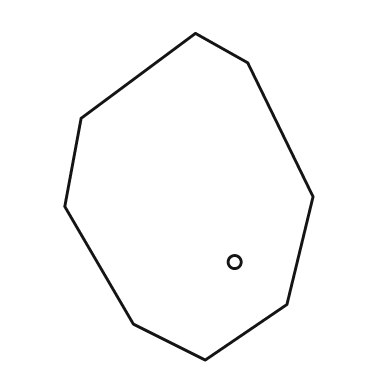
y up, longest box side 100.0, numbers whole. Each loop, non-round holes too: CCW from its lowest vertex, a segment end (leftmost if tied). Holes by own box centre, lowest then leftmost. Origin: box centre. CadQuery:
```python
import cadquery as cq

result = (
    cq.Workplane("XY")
    .moveTo(5.0, -50.0)
    .lineTo(30.0, -33.0)
    .lineTo(38.0, 0.0)
    .lineTo(18.0, 41.0)
    .lineTo(2.0, 50.0)
    .lineTo(-33.0, 24.0)
    .lineTo(-38.0, -3.0)
    .lineTo(-17.0, -39.0)
    .close()
    .moveTo(14.0, -20.0)
    .circle(2.0)
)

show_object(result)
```